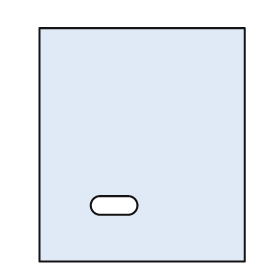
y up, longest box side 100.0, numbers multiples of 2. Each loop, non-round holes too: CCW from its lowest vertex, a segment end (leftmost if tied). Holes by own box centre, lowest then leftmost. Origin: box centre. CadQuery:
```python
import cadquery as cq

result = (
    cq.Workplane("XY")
    .moveTo(-44.0, -50.0)
    .lineTo(44.0, -50.0)
    .lineTo(44.0, 50.0)
    .lineTo(-44.0, 50.0)
    .close()
    .moveTo(-18.0, -30.0)
    .lineTo(-6.0, -30.0)
    .threePointArc((-2.0, -26.0), (-6.0, -22.0))
    .lineTo(-18.0, -22.0)
    .threePointArc((-22.0, -26.0), (-18.0, -30.0))
    .close()
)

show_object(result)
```